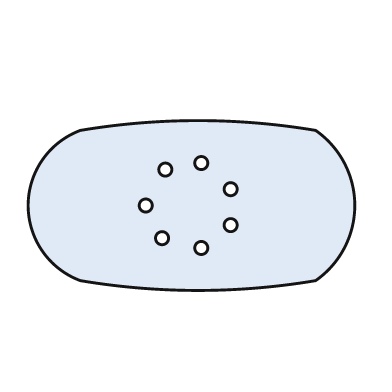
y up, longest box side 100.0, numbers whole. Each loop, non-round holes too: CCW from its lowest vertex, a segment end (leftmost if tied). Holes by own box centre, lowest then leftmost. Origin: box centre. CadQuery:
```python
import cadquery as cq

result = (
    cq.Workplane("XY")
    .moveTo(-34.0, -23.0)
    .threePointArc((2.0, -26.0), (38.0, -23.0))
    .threePointArc((50.0, 0.0), (38.0, 23.0))
    .threePointArc((2.0, 26.0), (-34.0, 23.0))
    .threePointArc((-50.0, 0.0), (-34.0, -23.0))
    .close()
    .moveTo(3.0, -13.0)
    .circle(2.0)
    .moveTo(-9.0, -10.0)
    .circle(2.0)
    .moveTo(12.0, -6.0)
    .circle(2.0)
    .moveTo(-14.0, 0.0)
    .circle(2.0)
    .moveTo(12.0, 5.0)
    .circle(2.0)
    .moveTo(-8.0, 11.0)
    .circle(2.0)
    .moveTo(3.0, 13.0)
    .circle(2.0)
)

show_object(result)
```